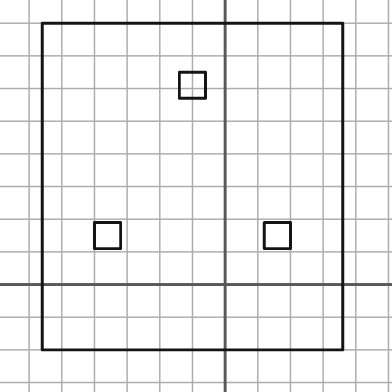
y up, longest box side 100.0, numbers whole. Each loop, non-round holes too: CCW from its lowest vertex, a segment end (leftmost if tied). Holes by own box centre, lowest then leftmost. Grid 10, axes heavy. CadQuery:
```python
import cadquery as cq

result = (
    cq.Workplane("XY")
    .moveTo(-56.0, -20.0)
    .lineTo(36.0, -20.0)
    .lineTo(36.0, 80.0)
    .lineTo(-56.0, 80.0)
    .close()
    .moveTo(-40.0, 11.0)
    .lineTo(-32.0, 11.0)
    .lineTo(-32.0, 19.0)
    .lineTo(-40.0, 19.0)
    .close()
    .moveTo(12.0, 11.0)
    .lineTo(20.0, 11.0)
    .lineTo(20.0, 19.0)
    .lineTo(12.0, 19.0)
    .close()
    .moveTo(-14.0, 57.0)
    .lineTo(-6.0, 57.0)
    .lineTo(-6.0, 65.0)
    .lineTo(-14.0, 65.0)
    .close()
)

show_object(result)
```